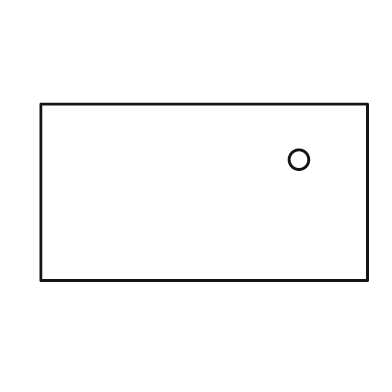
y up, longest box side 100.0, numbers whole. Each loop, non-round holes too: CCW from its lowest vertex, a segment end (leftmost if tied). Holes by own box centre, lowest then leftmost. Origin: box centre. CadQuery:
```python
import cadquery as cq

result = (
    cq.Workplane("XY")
    .moveTo(-50.0, -27.0)
    .lineTo(50.0, -27.0)
    .lineTo(50.0, 27.0)
    .lineTo(-50.0, 27.0)
    .close()
    .moveTo(29.0, 10.0)
    .circle(3.0)
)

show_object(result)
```